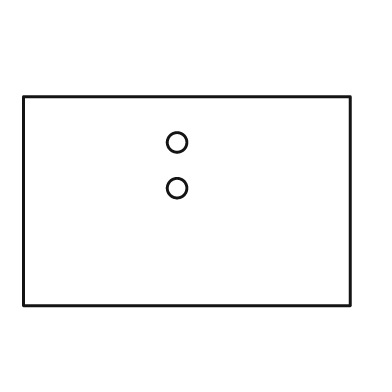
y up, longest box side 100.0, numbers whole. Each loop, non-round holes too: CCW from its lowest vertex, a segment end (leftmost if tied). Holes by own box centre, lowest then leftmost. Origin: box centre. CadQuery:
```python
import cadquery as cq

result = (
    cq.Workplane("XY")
    .moveTo(-50.0, -32.0)
    .lineTo(50.0, -32.0)
    .lineTo(50.0, 32.0)
    .lineTo(-50.0, 32.0)
    .close()
    .moveTo(-3.0, 4.0)
    .circle(3.0)
    .moveTo(-3.0, 18.0)
    .circle(3.0)
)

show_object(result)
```